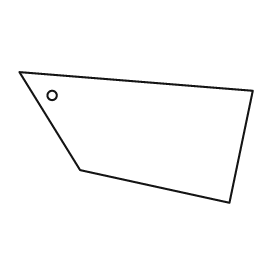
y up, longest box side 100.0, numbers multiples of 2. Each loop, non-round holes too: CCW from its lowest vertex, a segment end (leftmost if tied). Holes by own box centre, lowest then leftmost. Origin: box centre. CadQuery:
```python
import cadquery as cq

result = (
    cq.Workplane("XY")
    .moveTo(40.0, -28.0)
    .lineTo(50.0, 20.0)
    .lineTo(-50.0, 28.0)
    .lineTo(-24.0, -14.0)
    .close()
    .moveTo(-36.0, 18.0)
    .circle(2.0)
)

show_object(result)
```